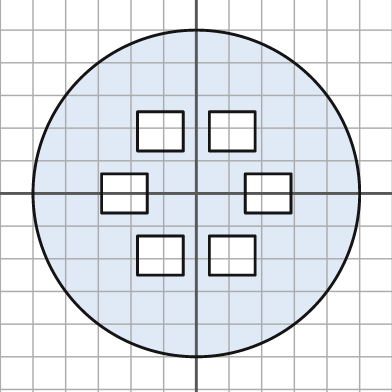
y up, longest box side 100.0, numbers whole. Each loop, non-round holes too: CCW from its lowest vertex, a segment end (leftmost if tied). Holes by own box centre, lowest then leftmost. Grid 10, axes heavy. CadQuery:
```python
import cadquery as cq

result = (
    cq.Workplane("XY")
    .moveTo(0.0, 0.0)
    .circle(50.0)
    .moveTo(-18.0, -25.0)
    .lineTo(-4.0, -25.0)
    .lineTo(-4.0, -13.0)
    .lineTo(-18.0, -13.0)
    .close()
    .moveTo(4.0, -25.0)
    .lineTo(18.0, -25.0)
    .lineTo(18.0, -13.0)
    .lineTo(4.0, -13.0)
    .close()
    .moveTo(-29.0, -6.0)
    .lineTo(-15.0, -6.0)
    .lineTo(-15.0, 6.0)
    .lineTo(-29.0, 6.0)
    .close()
    .moveTo(15.0, -6.0)
    .lineTo(29.0, -6.0)
    .lineTo(29.0, 6.0)
    .lineTo(15.0, 6.0)
    .close()
    .moveTo(-18.0, 13.0)
    .lineTo(-4.0, 13.0)
    .lineTo(-4.0, 25.0)
    .lineTo(-18.0, 25.0)
    .close()
    .moveTo(4.0, 13.0)
    .lineTo(18.0, 13.0)
    .lineTo(18.0, 25.0)
    .lineTo(4.0, 25.0)
    .close()
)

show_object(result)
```